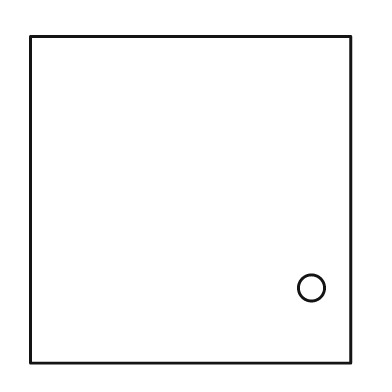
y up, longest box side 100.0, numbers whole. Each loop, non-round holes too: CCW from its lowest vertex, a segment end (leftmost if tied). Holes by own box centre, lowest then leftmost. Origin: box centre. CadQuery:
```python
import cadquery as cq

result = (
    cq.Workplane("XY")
    .moveTo(-49.0, -50.0)
    .lineTo(49.0, -50.0)
    .lineTo(49.0, 50.0)
    .lineTo(-49.0, 50.0)
    .close()
    .moveTo(37.0, -27.0)
    .circle(4.0)
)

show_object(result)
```